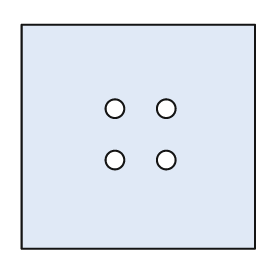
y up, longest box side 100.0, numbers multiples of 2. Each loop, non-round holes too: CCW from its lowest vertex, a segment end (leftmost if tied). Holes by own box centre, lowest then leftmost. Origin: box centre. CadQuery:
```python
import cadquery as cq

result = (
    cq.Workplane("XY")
    .moveTo(-50.0, -48.0)
    .lineTo(50.0, -48.0)
    .lineTo(50.0, 48.0)
    .lineTo(-50.0, 48.0)
    .close()
    .moveTo(-10.0, -10.0)
    .circle(4.0)
    .moveTo(12.0, -10.0)
    .circle(4.0)
    .moveTo(-10.0, 12.0)
    .circle(4.0)
    .moveTo(12.0, 12.0)
    .circle(4.0)
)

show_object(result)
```